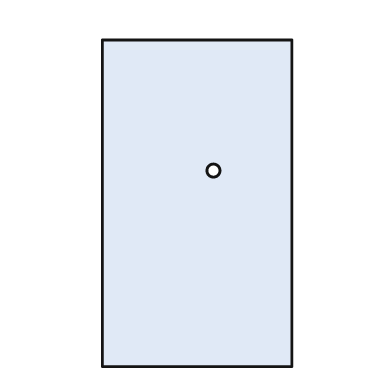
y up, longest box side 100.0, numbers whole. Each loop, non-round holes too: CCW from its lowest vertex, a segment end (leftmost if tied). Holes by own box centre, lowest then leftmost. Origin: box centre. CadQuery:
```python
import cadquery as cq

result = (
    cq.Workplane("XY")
    .moveTo(-29.0, -50.0)
    .lineTo(29.0, -50.0)
    .lineTo(29.0, 50.0)
    .lineTo(-29.0, 50.0)
    .close()
    .moveTo(5.0, 10.0)
    .circle(2.0)
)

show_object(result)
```